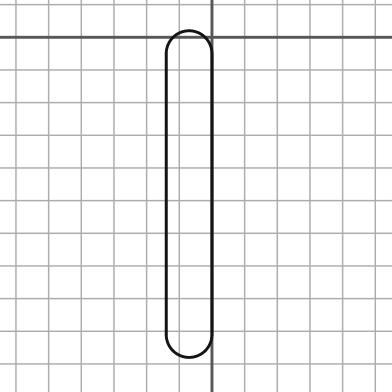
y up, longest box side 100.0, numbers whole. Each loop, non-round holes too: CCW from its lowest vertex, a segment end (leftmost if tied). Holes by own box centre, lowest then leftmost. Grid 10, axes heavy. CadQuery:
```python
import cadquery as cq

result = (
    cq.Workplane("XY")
    .moveTo(-14.0, -91.0)
    .threePointArc((-7.0, -98.0), (0.0, -91.0))
    .lineTo(0.0, -5.0)
    .threePointArc((-7.0, 2.0), (-14.0, -5.0))
    .close()
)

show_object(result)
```